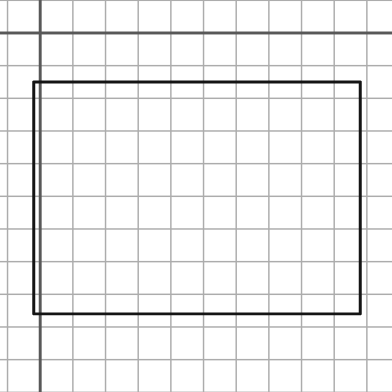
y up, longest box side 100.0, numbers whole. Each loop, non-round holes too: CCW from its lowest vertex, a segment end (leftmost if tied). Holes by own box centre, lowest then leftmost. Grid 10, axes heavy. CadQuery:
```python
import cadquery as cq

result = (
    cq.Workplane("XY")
    .moveTo(-2.0, -86.0)
    .lineTo(98.0, -86.0)
    .lineTo(98.0, -15.0)
    .lineTo(-2.0, -15.0)
    .close()
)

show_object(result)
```